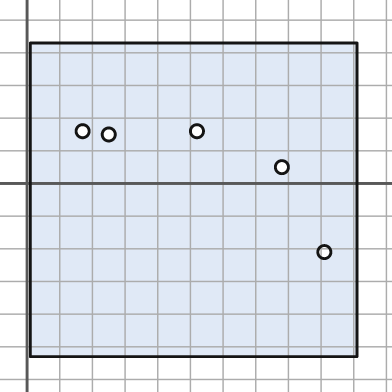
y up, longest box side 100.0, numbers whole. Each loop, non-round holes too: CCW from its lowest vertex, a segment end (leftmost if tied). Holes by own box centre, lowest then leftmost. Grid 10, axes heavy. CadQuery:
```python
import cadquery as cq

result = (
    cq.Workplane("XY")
    .moveTo(1.0, -53.0)
    .lineTo(101.0, -53.0)
    .lineTo(101.0, 43.0)
    .lineTo(1.0, 43.0)
    .close()
    .moveTo(91.0, -21.0)
    .circle(2.0)
    .moveTo(78.0, 5.0)
    .circle(2.0)
    .moveTo(25.0, 15.0)
    .circle(2.0)
    .moveTo(17.0, 16.0)
    .circle(2.0)
    .moveTo(52.0, 16.0)
    .circle(2.0)
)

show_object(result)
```